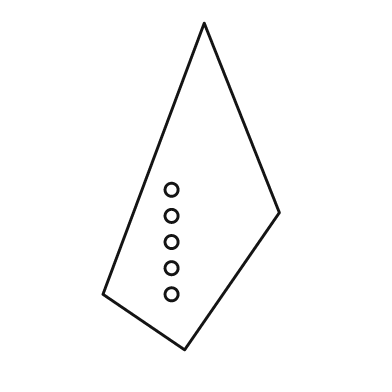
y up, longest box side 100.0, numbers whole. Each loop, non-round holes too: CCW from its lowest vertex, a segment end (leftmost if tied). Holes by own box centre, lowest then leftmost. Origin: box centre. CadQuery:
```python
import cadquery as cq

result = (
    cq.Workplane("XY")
    .moveTo(-2.0, -50.0)
    .lineTo(27.0, -8.0)
    .lineTo(4.0, 50.0)
    .lineTo(-27.0, -33.0)
    .close()
    .moveTo(-6.0, -33.0)
    .circle(2.0)
    .moveTo(-6.0, -25.0)
    .circle(2.0)
    .moveTo(-6.0, -17.0)
    .circle(2.0)
    .moveTo(-6.0, -9.0)
    .circle(2.0)
    .moveTo(-6.0, -1.0)
    .circle(2.0)
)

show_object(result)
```